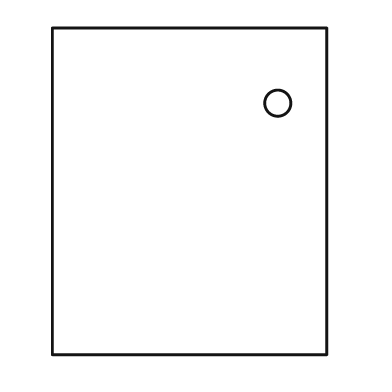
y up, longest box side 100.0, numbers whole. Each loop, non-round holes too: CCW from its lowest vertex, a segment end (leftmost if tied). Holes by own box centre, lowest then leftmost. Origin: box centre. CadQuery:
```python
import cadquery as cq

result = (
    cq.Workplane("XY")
    .moveTo(-42.0, -50.0)
    .lineTo(42.0, -50.0)
    .lineTo(42.0, 50.0)
    .lineTo(-42.0, 50.0)
    .close()
    .moveTo(27.0, 27.0)
    .circle(4.0)
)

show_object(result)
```